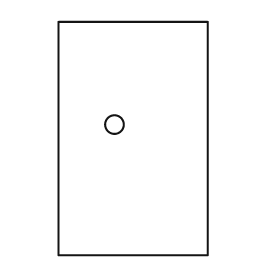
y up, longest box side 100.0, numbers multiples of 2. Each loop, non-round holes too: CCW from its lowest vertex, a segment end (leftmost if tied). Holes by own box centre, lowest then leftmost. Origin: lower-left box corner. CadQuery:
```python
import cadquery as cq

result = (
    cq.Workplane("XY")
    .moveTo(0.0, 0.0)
    .lineTo(64.0, 0.0)
    .lineTo(64.0, 100.0)
    .lineTo(0.0, 100.0)
    .close()
    .moveTo(24.0, 56.0)
    .circle(4.0)
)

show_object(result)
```